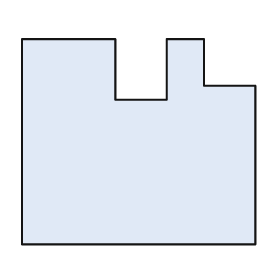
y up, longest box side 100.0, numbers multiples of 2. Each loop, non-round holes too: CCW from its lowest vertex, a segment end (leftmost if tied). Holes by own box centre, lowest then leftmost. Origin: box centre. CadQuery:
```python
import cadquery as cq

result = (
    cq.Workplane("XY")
    .moveTo(-50.0, -44.0)
    .lineTo(50.0, -44.0)
    .lineTo(50.0, 24.0)
    .lineTo(28.0, 24.0)
    .lineTo(28.0, 44.0)
    .lineTo(12.0, 44.0)
    .lineTo(12.0, 18.0)
    .lineTo(-10.0, 18.0)
    .lineTo(-10.0, 44.0)
    .lineTo(-50.0, 44.0)
    .close()
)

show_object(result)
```